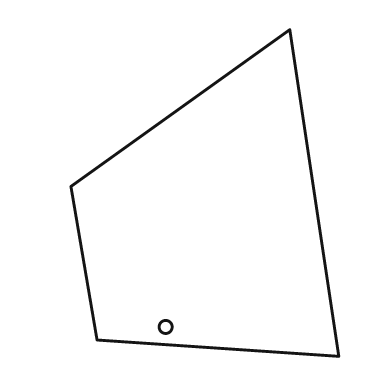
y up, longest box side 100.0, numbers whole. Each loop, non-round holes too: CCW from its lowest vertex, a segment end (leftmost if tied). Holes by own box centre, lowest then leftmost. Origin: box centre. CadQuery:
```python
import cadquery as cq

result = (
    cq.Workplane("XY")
    .moveTo(41.0, -50.0)
    .lineTo(26.0, 50.0)
    .lineTo(-41.0, 2.0)
    .lineTo(-33.0, -45.0)
    .close()
    .moveTo(-12.0, -41.0)
    .circle(2.0)
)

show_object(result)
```